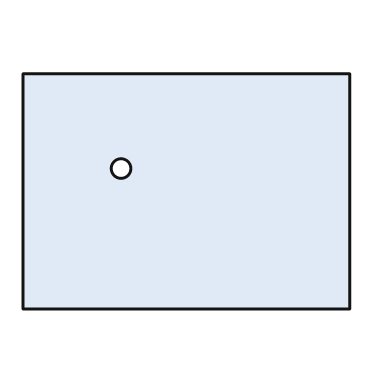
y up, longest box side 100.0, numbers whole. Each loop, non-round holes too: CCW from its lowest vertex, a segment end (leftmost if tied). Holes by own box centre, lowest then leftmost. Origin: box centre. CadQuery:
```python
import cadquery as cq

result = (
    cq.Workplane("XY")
    .moveTo(-50.0, -36.0)
    .lineTo(50.0, -36.0)
    .lineTo(50.0, 36.0)
    .lineTo(-50.0, 36.0)
    .close()
    .moveTo(-20.0, 7.0)
    .circle(3.0)
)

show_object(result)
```